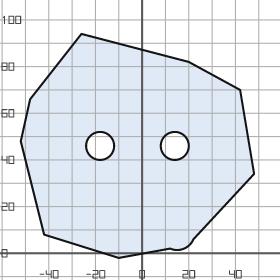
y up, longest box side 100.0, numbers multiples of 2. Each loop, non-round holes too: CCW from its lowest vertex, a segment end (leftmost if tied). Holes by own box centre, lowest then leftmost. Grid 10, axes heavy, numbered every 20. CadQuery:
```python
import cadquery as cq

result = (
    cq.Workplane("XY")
    .moveTo(-10.0, -2.0)
    .lineTo(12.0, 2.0)
    .threePointArc((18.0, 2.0), (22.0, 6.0))
    .lineTo(48.0, 34.0)
    .lineTo(42.0, 70.0)
    .lineTo(20.0, 82.0)
    .lineTo(-26.0, 94.0)
    .lineTo(-48.0, 66.0)
    .lineTo(-52.0, 48.0)
    .lineTo(-42.0, 8.0)
    .close()
    .moveTo(-18.0, 46.0)
    .circle(6.0)
    .moveTo(14.0, 46.0)
    .circle(6.0)
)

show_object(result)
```